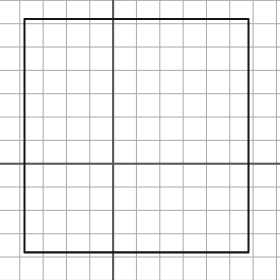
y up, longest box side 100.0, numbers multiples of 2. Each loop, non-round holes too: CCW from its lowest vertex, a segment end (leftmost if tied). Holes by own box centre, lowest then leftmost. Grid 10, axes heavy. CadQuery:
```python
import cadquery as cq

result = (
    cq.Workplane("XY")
    .moveTo(-38.0, -38.0)
    .lineTo(58.0, -38.0)
    .lineTo(58.0, 62.0)
    .lineTo(-38.0, 62.0)
    .close()
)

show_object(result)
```